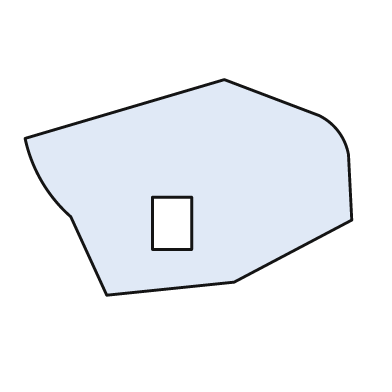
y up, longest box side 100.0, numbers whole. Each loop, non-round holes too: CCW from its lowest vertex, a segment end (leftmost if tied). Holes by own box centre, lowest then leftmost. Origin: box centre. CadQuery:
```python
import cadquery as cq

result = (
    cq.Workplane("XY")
    .moveTo(-25.0, -33.0)
    .lineTo(14.0, -29.0)
    .lineTo(50.0, -10.0)
    .lineTo(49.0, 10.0)
    .threePointArc((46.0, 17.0), (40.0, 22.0))
    .lineTo(11.0, 33.0)
    .lineTo(-50.0, 15.0)
    .threePointArc((-45.0, 2.0), (-36.0, -9.0))
    .close()
    .moveTo(-11.0, -19.0)
    .lineTo(1.0, -19.0)
    .lineTo(1.0, -3.0)
    .lineTo(-11.0, -3.0)
    .close()
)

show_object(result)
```